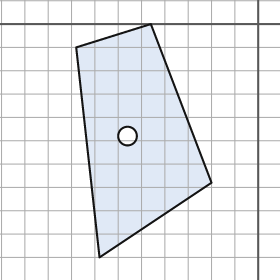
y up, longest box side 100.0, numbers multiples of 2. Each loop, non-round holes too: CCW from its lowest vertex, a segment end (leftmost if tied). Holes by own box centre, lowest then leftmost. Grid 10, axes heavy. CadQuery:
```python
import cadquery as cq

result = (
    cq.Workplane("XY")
    .moveTo(-68.0, -100.0)
    .lineTo(-20.0, -68.0)
    .lineTo(-46.0, 0.0)
    .lineTo(-78.0, -10.0)
    .close()
    .moveTo(-56.0, -48.0)
    .circle(4.0)
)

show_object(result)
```